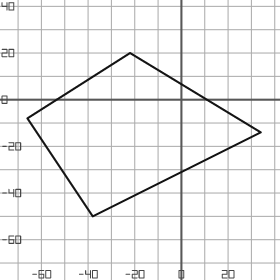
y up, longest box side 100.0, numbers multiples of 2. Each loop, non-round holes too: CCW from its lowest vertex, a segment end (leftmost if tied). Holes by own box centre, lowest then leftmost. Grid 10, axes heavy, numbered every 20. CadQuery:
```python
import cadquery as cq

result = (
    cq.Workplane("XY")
    .moveTo(-38.0, -50.0)
    .lineTo(34.0, -14.0)
    .lineTo(-22.0, 20.0)
    .lineTo(-66.0, -8.0)
    .close()
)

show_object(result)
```